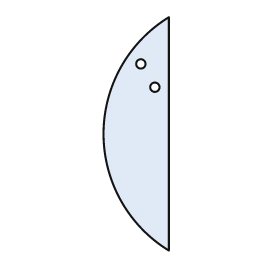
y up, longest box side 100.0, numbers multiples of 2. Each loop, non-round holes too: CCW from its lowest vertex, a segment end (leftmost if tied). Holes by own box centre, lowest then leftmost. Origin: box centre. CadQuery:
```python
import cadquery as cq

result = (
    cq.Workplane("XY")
    .moveTo(14.0, -50.0)
    .lineTo(14.0, 50.0)
    .threePointArc((-14.0, 0.0), (14.0, -50.0))
    .close()
    .moveTo(8.0, 20.0)
    .circle(2.0)
    .moveTo(2.0, 30.0)
    .circle(2.0)
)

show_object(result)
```